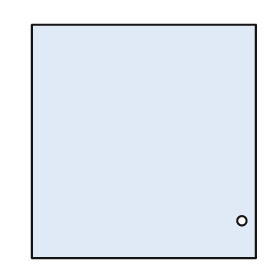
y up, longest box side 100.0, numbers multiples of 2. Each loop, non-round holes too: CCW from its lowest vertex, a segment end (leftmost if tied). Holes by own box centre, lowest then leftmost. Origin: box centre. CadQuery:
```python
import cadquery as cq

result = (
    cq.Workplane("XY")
    .moveTo(-48.0, -50.0)
    .lineTo(48.0, -50.0)
    .lineTo(48.0, 50.0)
    .lineTo(-48.0, 50.0)
    .close()
    .moveTo(42.0, -34.0)
    .circle(2.0)
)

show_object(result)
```